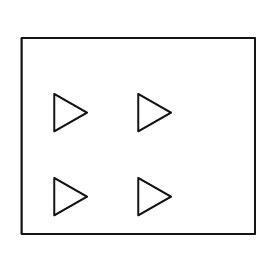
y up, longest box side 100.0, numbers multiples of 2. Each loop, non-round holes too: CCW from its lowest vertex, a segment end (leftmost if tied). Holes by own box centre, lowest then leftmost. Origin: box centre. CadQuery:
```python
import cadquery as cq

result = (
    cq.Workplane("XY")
    .moveTo(-50.0, -42.0)
    .lineTo(50.0, -42.0)
    .lineTo(50.0, 42.0)
    .lineTo(-50.0, 42.0)
    .close()
    .moveTo(-36.0, -34.0)
    .lineTo(-22.0, -26.0)
    .lineTo(-36.0, -18.0)
    .close()
    .moveTo(0.0, -34.0)
    .lineTo(14.0, -26.0)
    .lineTo(0.0, -18.0)
    .close()
    .moveTo(-36.0, 2.0)
    .lineTo(-22.0, 10.0)
    .lineTo(-36.0, 18.0)
    .close()
    .moveTo(0.0, 2.0)
    .lineTo(14.0, 10.0)
    .lineTo(0.0, 18.0)
    .close()
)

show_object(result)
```